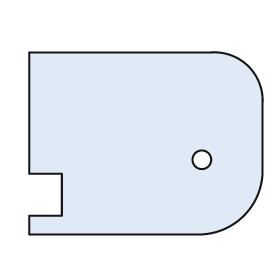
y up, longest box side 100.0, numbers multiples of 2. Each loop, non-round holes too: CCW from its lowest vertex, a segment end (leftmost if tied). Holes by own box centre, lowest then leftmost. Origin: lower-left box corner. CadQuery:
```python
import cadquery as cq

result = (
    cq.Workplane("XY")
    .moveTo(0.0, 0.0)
    .lineTo(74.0, 0.0)
    .threePointArc((92.0, 8.0), (100.0, 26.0))
    .lineTo(100.0, 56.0)
    .threePointArc((94.0, 72.0), (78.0, 78.0))
    .lineTo(0.0, 78.0)
    .lineTo(0.0, 26.0)
    .lineTo(14.0, 26.0)
    .lineTo(14.0, 8.0)
    .lineTo(0.0, 8.0)
    .close()
    .moveTo(74.0, 32.0)
    .circle(4.0)
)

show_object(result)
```